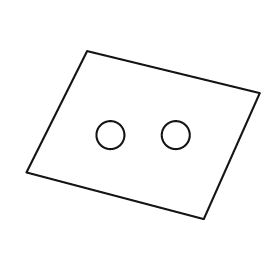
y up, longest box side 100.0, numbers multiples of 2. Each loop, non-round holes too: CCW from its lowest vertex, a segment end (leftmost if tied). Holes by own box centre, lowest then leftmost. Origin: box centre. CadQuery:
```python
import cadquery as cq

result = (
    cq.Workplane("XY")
    .moveTo(26.0, -36.0)
    .lineTo(50.0, 18.0)
    .lineTo(-24.0, 36.0)
    .lineTo(-50.0, -16.0)
    .close()
    .moveTo(-14.0, 0.0)
    .circle(6.0)
    .moveTo(14.0, 0.0)
    .circle(6.0)
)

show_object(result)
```